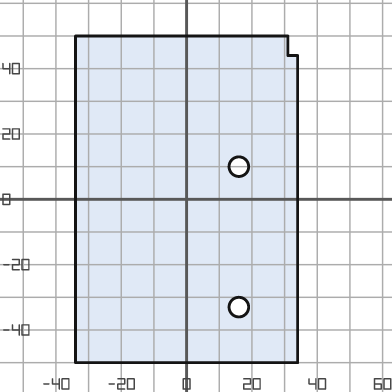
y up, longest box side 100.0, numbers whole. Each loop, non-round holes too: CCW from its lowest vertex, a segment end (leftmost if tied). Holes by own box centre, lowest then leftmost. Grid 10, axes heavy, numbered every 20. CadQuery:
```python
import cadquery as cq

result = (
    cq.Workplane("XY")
    .moveTo(-34.0, -50.0)
    .lineTo(34.0, -50.0)
    .lineTo(34.0, 44.0)
    .lineTo(31.0, 44.0)
    .lineTo(31.0, 50.0)
    .lineTo(-34.0, 50.0)
    .close()
    .moveTo(16.0, -33.0)
    .circle(3.0)
    .moveTo(16.0, 10.0)
    .circle(3.0)
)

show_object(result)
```